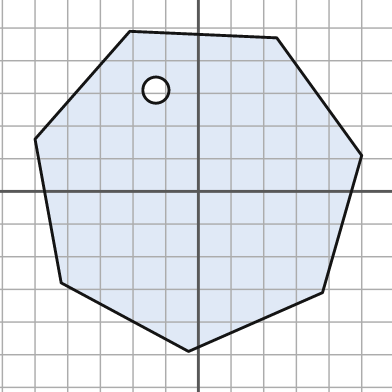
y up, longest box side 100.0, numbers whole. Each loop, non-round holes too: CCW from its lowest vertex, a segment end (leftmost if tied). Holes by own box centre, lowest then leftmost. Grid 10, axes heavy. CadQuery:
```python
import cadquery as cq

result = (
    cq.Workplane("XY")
    .moveTo(-3.0, -49.0)
    .lineTo(38.0, -31.0)
    .lineTo(50.0, 11.0)
    .lineTo(24.0, 47.0)
    .lineTo(-21.0, 49.0)
    .lineTo(-50.0, 16.0)
    .lineTo(-42.0, -28.0)
    .close()
    .moveTo(-13.0, 31.0)
    .circle(4.0)
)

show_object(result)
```